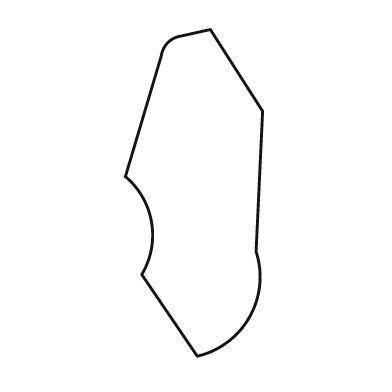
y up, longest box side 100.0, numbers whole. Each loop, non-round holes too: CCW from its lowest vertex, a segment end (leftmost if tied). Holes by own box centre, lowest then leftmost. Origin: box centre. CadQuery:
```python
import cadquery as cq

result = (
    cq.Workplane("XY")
    .moveTo(1.0, -50.0)
    .threePointArc((17.0, -38.0), (19.0, -18.0))
    .lineTo(21.0, 25.0)
    .lineTo(5.0, 50.0)
    .lineTo(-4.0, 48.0)
    .threePointArc((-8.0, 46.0), (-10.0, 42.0))
    .lineTo(-21.0, 5.0)
    .threePointArc((-13.0, -9.0), (-16.0, -25.0))
    .close()
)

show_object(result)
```